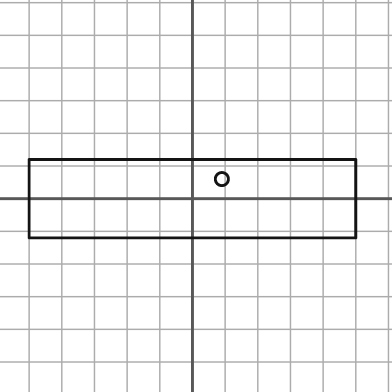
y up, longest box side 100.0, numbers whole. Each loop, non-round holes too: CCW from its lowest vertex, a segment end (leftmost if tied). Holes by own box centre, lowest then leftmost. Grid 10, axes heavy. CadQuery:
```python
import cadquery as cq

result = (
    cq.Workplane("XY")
    .moveTo(-50.0, -12.0)
    .lineTo(50.0, -12.0)
    .lineTo(50.0, 12.0)
    .lineTo(-50.0, 12.0)
    .close()
    .moveTo(9.0, 6.0)
    .circle(2.0)
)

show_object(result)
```